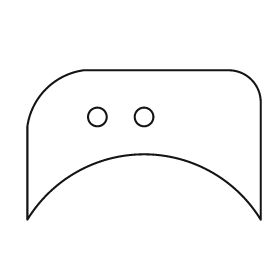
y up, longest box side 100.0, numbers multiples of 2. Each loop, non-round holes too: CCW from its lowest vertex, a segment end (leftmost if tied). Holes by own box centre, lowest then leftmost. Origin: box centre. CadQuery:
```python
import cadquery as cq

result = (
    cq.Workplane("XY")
    .moveTo(-50.0, -32.0)
    .threePointArc((0.0, -4.0), (50.0, -32.0))
    .lineTo(50.0, 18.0)
    .threePointArc((46.0, 28.0), (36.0, 32.0))
    .lineTo(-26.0, 32.0)
    .threePointArc((-42.0, 24.0), (-50.0, 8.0))
    .close()
    .moveTo(-20.0, 12.0)
    .circle(4.0)
    .moveTo(0.0, 12.0)
    .circle(4.0)
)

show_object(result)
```